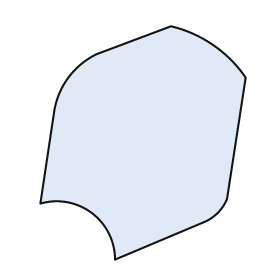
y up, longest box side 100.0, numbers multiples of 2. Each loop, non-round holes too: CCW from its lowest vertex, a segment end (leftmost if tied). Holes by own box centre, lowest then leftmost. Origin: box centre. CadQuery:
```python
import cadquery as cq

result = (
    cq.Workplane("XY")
    .moveTo(-12.0, -50.0)
    .lineTo(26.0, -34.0)
    .threePointArc((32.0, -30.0), (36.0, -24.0))
    .lineTo(44.0, 28.0)
    .threePointArc((30.0, 42.0), (12.0, 50.0))
    .lineTo(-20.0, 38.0)
    .threePointArc((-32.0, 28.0), (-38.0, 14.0))
    .lineTo(-44.0, -26.0)
    .threePointArc((-22.0, -30.0), (-12.0, -50.0))
    .close()
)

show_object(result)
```